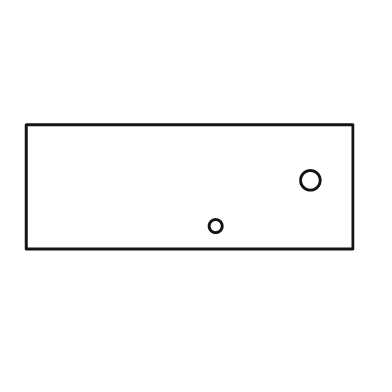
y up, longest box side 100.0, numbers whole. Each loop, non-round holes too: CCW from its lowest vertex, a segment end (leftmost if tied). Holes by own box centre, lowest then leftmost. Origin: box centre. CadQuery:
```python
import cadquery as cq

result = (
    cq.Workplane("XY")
    .moveTo(-50.0, -19.0)
    .lineTo(50.0, -19.0)
    .lineTo(50.0, 19.0)
    .lineTo(-50.0, 19.0)
    .close()
    .moveTo(8.0, -12.0)
    .circle(2.0)
    .moveTo(37.0, 2.0)
    .circle(3.0)
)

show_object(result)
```